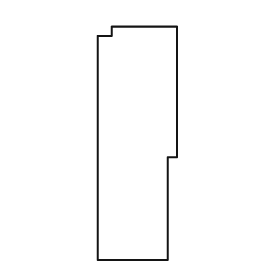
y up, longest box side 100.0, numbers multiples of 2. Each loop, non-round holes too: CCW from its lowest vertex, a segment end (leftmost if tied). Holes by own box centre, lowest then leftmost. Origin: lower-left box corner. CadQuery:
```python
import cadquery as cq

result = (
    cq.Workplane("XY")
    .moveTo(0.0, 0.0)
    .lineTo(30.0, 0.0)
    .lineTo(30.0, 44.0)
    .lineTo(34.0, 44.0)
    .lineTo(34.0, 100.0)
    .lineTo(6.0, 100.0)
    .lineTo(6.0, 96.0)
    .lineTo(0.0, 96.0)
    .close()
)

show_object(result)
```